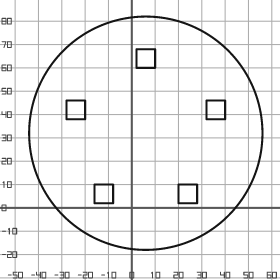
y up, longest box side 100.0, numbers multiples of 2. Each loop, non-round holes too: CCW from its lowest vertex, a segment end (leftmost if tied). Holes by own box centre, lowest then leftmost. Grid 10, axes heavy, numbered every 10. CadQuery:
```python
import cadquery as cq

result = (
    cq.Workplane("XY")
    .moveTo(6.0, 32.0)
    .circle(50.0)
    .moveTo(-16.0, 2.0)
    .lineTo(-8.0, 2.0)
    .lineTo(-8.0, 10.0)
    .lineTo(-16.0, 10.0)
    .close()
    .moveTo(20.0, 2.0)
    .lineTo(28.0, 2.0)
    .lineTo(28.0, 10.0)
    .lineTo(20.0, 10.0)
    .close()
    .moveTo(-28.0, 38.0)
    .lineTo(-20.0, 38.0)
    .lineTo(-20.0, 46.0)
    .lineTo(-28.0, 46.0)
    .close()
    .moveTo(32.0, 38.0)
    .lineTo(40.0, 38.0)
    .lineTo(40.0, 46.0)
    .lineTo(32.0, 46.0)
    .close()
    .moveTo(2.0, 60.0)
    .lineTo(10.0, 60.0)
    .lineTo(10.0, 68.0)
    .lineTo(2.0, 68.0)
    .close()
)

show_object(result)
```